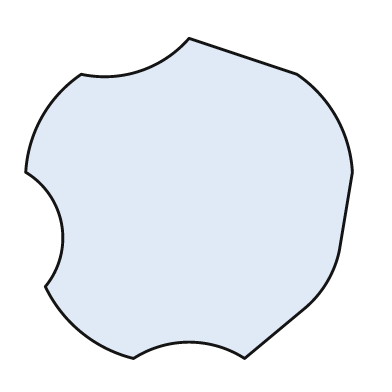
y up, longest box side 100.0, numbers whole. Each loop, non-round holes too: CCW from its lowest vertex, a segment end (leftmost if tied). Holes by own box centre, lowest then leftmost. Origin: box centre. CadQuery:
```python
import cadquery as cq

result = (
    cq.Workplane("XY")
    .moveTo(-17.0, -49.0)
    .threePointArc((0.0, -44.0), (17.0, -49.0))
    .lineTo(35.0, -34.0)
    .threePointArc((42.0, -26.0), (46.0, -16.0))
    .lineTo(50.0, 8.0)
    .threePointArc((45.0, 25.0), (33.0, 38.0))
    .lineTo(0.0, 49.0)
    .threePointArc((-15.0, 39.0), (-33.0, 38.0))
    .threePointArc((-45.0, 25.0), (-50.0, 8.0))
    .threePointArc((-39.0, -8.0), (-44.0, -27.0))
    .threePointArc((-33.0, -41.0), (-17.0, -49.0))
    .close()
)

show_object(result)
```